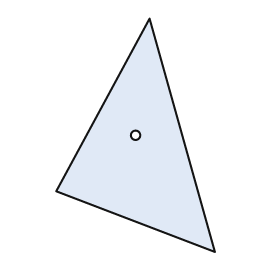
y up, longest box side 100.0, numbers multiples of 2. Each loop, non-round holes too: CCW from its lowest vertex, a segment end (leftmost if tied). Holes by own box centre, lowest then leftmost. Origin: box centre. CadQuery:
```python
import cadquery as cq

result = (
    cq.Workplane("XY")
    .moveTo(34.0, -50.0)
    .lineTo(6.0, 50.0)
    .lineTo(-34.0, -24.0)
    .close()
    .moveTo(0.0, 0.0)
    .circle(2.0)
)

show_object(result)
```